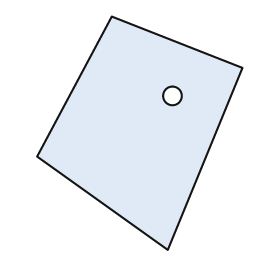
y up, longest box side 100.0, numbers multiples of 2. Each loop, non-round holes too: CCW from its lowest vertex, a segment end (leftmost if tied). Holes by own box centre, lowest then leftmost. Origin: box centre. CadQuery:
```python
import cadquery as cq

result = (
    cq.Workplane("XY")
    .moveTo(12.0, -50.0)
    .lineTo(44.0, 28.0)
    .lineTo(-12.0, 50.0)
    .lineTo(-44.0, -10.0)
    .close()
    .moveTo(14.0, 16.0)
    .circle(4.0)
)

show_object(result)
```